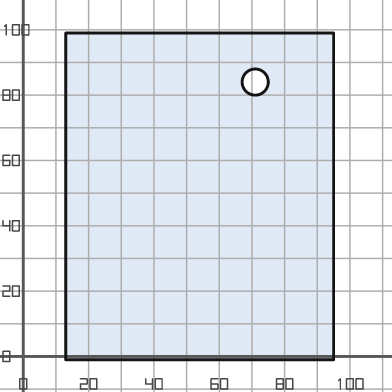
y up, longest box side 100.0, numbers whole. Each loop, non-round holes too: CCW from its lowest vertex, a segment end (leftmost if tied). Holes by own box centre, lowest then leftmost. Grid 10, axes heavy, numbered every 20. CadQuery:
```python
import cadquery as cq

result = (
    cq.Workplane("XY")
    .moveTo(13.0, -1.0)
    .lineTo(95.0, -1.0)
    .lineTo(95.0, 99.0)
    .lineTo(13.0, 99.0)
    .close()
    .moveTo(71.0, 84.0)
    .circle(4.0)
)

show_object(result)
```